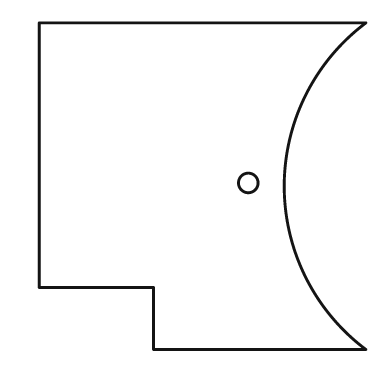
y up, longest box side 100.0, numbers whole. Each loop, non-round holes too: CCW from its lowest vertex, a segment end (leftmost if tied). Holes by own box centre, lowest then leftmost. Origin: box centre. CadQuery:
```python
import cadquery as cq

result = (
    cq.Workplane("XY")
    .moveTo(-15.0, -50.0)
    .lineTo(50.0, -50.0)
    .threePointArc((25.0, 0.0), (50.0, 50.0))
    .lineTo(-50.0, 50.0)
    .lineTo(-50.0, -31.0)
    .lineTo(-15.0, -31.0)
    .close()
    .moveTo(14.0, 1.0)
    .circle(3.0)
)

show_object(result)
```